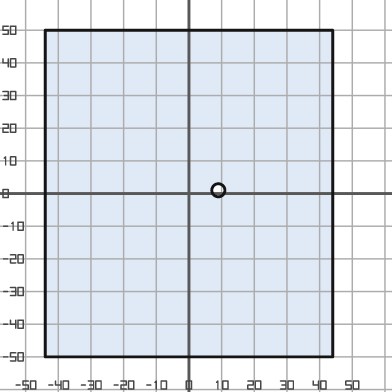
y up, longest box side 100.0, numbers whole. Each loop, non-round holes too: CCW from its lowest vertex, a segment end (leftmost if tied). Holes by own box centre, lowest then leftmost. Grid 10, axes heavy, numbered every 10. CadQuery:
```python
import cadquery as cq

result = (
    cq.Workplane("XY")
    .moveTo(-44.0, -50.0)
    .lineTo(44.0, -50.0)
    .lineTo(44.0, 50.0)
    .lineTo(-44.0, 50.0)
    .close()
    .moveTo(9.0, 1.0)
    .circle(2.0)
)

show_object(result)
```